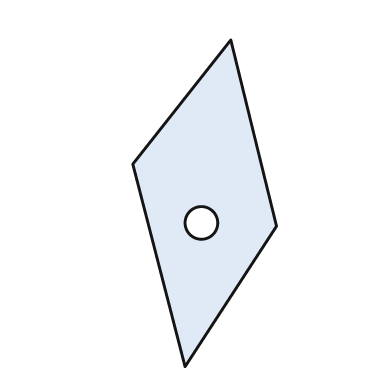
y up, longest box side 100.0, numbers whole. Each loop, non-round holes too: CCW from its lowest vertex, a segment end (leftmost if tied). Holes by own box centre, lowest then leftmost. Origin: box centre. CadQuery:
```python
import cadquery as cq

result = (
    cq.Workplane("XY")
    .moveTo(-6.0, -50.0)
    .lineTo(22.0, -7.0)
    .lineTo(8.0, 50.0)
    .lineTo(-22.0, 12.0)
    .close()
    .moveTo(-1.0, -6.0)
    .circle(5.0)
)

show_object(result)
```